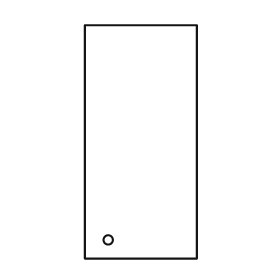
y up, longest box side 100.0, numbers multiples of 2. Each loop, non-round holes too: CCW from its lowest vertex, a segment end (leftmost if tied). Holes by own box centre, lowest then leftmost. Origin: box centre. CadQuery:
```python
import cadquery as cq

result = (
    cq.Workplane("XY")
    .moveTo(-24.0, -50.0)
    .lineTo(24.0, -50.0)
    .lineTo(24.0, 50.0)
    .lineTo(-24.0, 50.0)
    .close()
    .moveTo(-14.0, -42.0)
    .circle(2.0)
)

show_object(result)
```